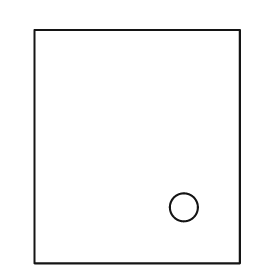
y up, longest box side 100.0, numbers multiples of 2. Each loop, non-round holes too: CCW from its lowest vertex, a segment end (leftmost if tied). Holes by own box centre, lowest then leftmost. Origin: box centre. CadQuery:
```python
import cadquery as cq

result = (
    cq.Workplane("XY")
    .moveTo(-44.0, -50.0)
    .lineTo(44.0, -50.0)
    .lineTo(44.0, 50.0)
    .lineTo(-44.0, 50.0)
    .close()
    .moveTo(20.0, -26.0)
    .circle(6.0)
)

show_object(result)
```